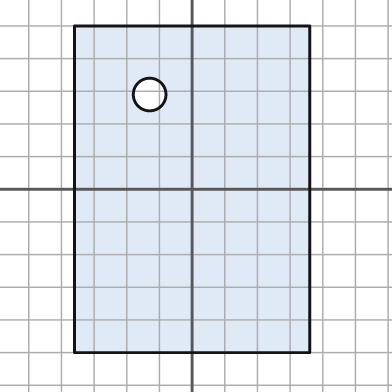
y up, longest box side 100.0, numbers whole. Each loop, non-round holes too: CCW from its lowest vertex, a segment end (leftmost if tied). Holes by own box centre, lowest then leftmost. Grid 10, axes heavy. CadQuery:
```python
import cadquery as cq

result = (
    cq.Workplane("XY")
    .moveTo(-36.0, -50.0)
    .lineTo(36.0, -50.0)
    .lineTo(36.0, 50.0)
    .lineTo(-36.0, 50.0)
    .close()
    .moveTo(-13.0, 29.0)
    .circle(5.0)
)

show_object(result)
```